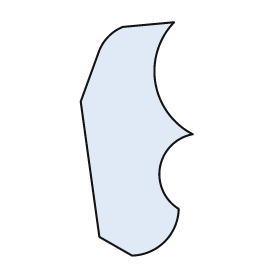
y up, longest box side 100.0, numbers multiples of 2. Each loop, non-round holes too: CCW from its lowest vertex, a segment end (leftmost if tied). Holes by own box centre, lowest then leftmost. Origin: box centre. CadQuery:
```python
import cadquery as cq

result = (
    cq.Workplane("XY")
    .moveTo(-2.0, -50.0)
    .threePointArc((12.0, -44.0), (18.0, -30.0))
    .threePointArc((10.0, -12.0), (24.0, 2.0))
    .threePointArc((8.0, 24.0), (16.0, 50.0))
    .lineTo(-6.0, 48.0)
    .threePointArc((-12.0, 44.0), (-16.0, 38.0))
    .lineTo(-24.0, 16.0)
    .lineTo(-16.0, -42.0)
    .close()
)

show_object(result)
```